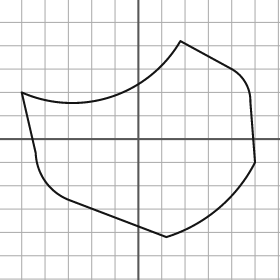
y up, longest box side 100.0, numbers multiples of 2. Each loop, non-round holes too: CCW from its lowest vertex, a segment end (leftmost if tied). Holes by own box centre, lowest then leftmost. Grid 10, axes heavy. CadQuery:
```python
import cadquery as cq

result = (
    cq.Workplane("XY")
    .moveTo(12.0, -42.0)
    .threePointArc((34.0, -30.0), (50.0, -10.0))
    .lineTo(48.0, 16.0)
    .threePointArc((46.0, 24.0), (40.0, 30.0))
    .lineTo(18.0, 42.0)
    .threePointArc((-12.0, 18.0), (-50.0, 20.0))
    .lineTo(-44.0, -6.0)
    .threePointArc((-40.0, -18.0), (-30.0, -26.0))
    .close()
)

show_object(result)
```